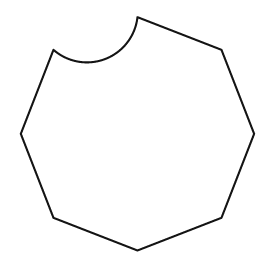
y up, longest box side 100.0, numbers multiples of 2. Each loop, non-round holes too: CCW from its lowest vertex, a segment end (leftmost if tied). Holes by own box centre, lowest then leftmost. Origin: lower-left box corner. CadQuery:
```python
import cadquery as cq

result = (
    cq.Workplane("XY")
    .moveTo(50.0, 0.0)
    .lineTo(86.0, 14.0)
    .lineTo(100.0, 50.0)
    .lineTo(86.0, 86.0)
    .lineTo(50.0, 100.0)
    .threePointArc((36.0, 82.0), (14.0, 86.0))
    .lineTo(0.0, 50.0)
    .lineTo(14.0, 14.0)
    .close()
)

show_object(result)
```